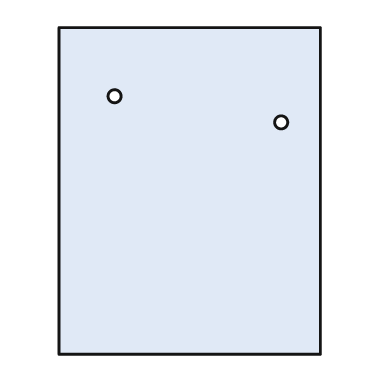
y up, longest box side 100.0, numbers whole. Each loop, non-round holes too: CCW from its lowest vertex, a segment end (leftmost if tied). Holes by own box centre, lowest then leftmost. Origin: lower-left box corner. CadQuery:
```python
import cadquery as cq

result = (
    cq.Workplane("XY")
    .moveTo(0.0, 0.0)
    .lineTo(80.0, 0.0)
    .lineTo(80.0, 100.0)
    .lineTo(0.0, 100.0)
    .close()
    .moveTo(68.0, 71.0)
    .circle(2.0)
    .moveTo(17.0, 79.0)
    .circle(2.0)
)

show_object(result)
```